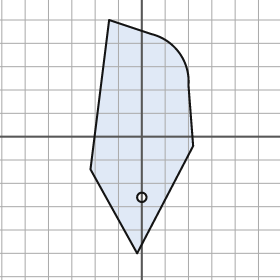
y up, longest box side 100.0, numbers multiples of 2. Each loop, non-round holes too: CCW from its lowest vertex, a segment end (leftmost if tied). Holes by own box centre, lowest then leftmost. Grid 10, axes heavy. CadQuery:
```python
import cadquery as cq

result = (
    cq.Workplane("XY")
    .moveTo(-2.0, -50.0)
    .lineTo(22.0, -4.0)
    .lineTo(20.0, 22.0)
    .threePointArc((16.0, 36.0), (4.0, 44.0))
    .lineTo(-14.0, 50.0)
    .lineTo(-22.0, -14.0)
    .close()
    .moveTo(0.0, -26.0)
    .circle(2.0)
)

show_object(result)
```